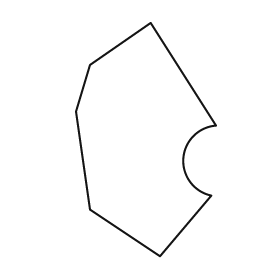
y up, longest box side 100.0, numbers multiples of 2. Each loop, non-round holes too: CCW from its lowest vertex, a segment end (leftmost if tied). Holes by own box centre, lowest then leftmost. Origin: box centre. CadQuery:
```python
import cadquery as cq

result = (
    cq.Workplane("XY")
    .moveTo(6.0, -50.0)
    .lineTo(28.0, -24.0)
    .threePointArc((16.0, -8.0), (30.0, 6.0))
    .lineTo(2.0, 50.0)
    .lineTo(-24.0, 32.0)
    .lineTo(-30.0, 12.0)
    .lineTo(-24.0, -30.0)
    .close()
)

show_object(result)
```